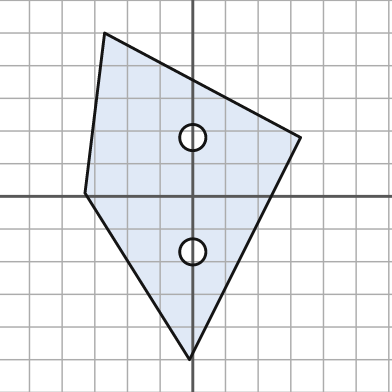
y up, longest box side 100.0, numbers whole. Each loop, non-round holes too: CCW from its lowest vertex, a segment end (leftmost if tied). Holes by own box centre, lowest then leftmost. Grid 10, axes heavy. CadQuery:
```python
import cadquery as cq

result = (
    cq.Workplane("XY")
    .moveTo(-1.0, -50.0)
    .lineTo(33.0, 18.0)
    .lineTo(-27.0, 50.0)
    .lineTo(-33.0, 1.0)
    .close()
    .moveTo(0.0, -17.0)
    .circle(4.0)
    .moveTo(0.0, 18.0)
    .circle(4.0)
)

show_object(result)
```